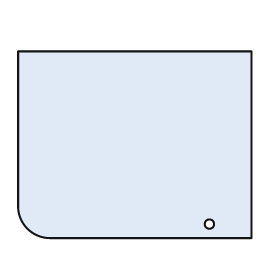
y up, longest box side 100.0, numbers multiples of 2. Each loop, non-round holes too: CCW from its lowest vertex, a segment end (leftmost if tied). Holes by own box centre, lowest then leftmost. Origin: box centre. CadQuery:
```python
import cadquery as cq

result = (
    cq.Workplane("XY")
    .moveTo(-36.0, -40.0)
    .lineTo(50.0, -40.0)
    .lineTo(50.0, 40.0)
    .lineTo(-50.0, 40.0)
    .lineTo(-50.0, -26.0)
    .threePointArc((-46.0, -36.0), (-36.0, -40.0))
    .close()
    .moveTo(32.0, -34.0)
    .circle(2.0)
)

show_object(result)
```